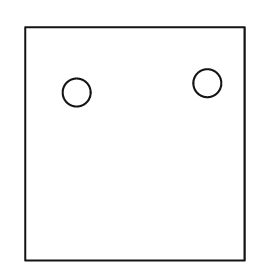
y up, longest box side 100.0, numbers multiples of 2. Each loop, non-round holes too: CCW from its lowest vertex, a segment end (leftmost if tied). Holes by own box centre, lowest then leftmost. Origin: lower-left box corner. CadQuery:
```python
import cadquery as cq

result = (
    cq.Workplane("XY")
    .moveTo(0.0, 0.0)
    .lineTo(94.0, 0.0)
    .lineTo(94.0, 100.0)
    .lineTo(0.0, 100.0)
    .close()
    .moveTo(22.0, 72.0)
    .circle(6.0)
    .moveTo(78.0, 76.0)
    .circle(6.0)
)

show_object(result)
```